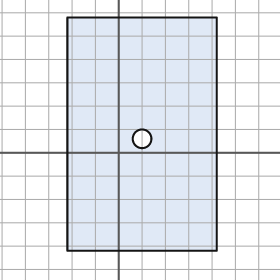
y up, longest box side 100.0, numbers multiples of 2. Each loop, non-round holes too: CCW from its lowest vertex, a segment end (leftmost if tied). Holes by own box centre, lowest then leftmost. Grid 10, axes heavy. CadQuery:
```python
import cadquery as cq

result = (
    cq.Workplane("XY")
    .moveTo(-22.0, -42.0)
    .lineTo(42.0, -42.0)
    .lineTo(42.0, 58.0)
    .lineTo(-22.0, 58.0)
    .close()
    .moveTo(10.0, 6.0)
    .circle(4.0)
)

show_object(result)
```